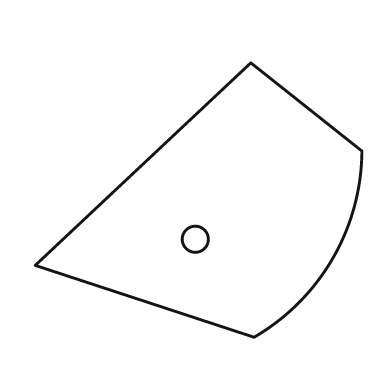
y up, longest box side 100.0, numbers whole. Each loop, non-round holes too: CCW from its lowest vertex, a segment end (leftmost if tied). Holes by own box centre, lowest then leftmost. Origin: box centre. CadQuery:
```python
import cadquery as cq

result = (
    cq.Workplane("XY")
    .moveTo(17.0, -42.0)
    .threePointArc((41.0, -18.0), (50.0, 15.0))
    .lineTo(16.0, 42.0)
    .lineTo(-50.0, -20.0)
    .close()
    .moveTo(-1.0, -12.0)
    .circle(4.0)
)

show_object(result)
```